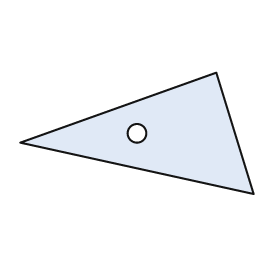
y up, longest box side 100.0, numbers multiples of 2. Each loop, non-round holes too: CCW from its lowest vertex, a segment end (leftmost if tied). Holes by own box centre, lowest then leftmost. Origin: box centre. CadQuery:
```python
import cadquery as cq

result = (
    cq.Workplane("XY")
    .moveTo(50.0, -26.0)
    .lineTo(34.0, 26.0)
    .lineTo(-50.0, -4.0)
    .close()
    .moveTo(0.0, 0.0)
    .circle(4.0)
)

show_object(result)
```